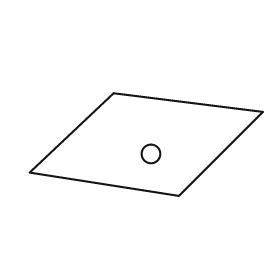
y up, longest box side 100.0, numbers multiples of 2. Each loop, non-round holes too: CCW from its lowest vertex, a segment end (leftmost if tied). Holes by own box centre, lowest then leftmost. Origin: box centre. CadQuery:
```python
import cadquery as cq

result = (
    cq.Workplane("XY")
    .moveTo(14.0, -22.0)
    .lineTo(50.0, 14.0)
    .lineTo(-14.0, 22.0)
    .lineTo(-50.0, -12.0)
    .close()
    .moveTo(2.0, -4.0)
    .circle(4.0)
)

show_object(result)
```